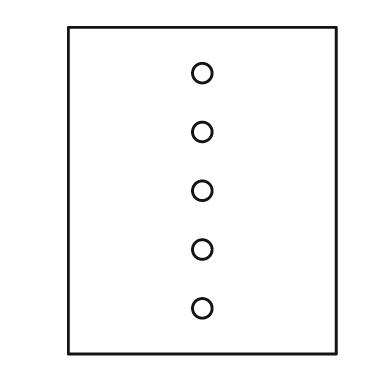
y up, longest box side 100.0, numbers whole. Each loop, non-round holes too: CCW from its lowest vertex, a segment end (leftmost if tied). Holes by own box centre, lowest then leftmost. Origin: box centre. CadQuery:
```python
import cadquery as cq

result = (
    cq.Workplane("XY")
    .moveTo(-41.0, -50.0)
    .lineTo(41.0, -50.0)
    .lineTo(41.0, 50.0)
    .lineTo(-41.0, 50.0)
    .close()
    .moveTo(0.0, -36.0)
    .circle(3.0)
    .moveTo(0.0, -18.0)
    .circle(3.0)
    .moveTo(0.0, 0.0)
    .circle(3.0)
    .moveTo(0.0, 18.0)
    .circle(3.0)
    .moveTo(0.0, 36.0)
    .circle(3.0)
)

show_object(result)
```